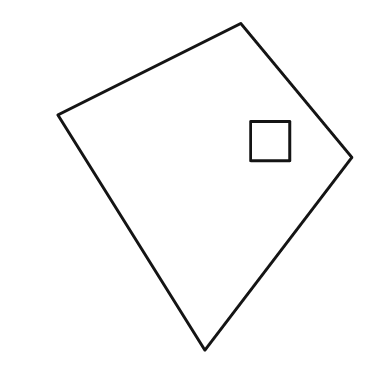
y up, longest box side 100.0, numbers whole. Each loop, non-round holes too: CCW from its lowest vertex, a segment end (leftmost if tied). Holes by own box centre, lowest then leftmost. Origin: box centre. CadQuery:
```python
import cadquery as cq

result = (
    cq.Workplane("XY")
    .moveTo(0.0, -50.0)
    .lineTo(45.0, 9.0)
    .lineTo(11.0, 50.0)
    .lineTo(-45.0, 22.0)
    .close()
    .moveTo(14.0, 8.0)
    .lineTo(26.0, 8.0)
    .lineTo(26.0, 20.0)
    .lineTo(14.0, 20.0)
    .close()
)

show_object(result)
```